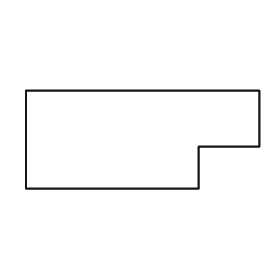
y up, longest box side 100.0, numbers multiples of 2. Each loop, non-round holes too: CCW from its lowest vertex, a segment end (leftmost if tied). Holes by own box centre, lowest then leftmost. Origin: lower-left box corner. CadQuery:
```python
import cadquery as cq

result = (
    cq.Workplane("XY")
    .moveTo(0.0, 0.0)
    .lineTo(74.0, 0.0)
    .lineTo(74.0, 18.0)
    .lineTo(100.0, 18.0)
    .lineTo(100.0, 42.0)
    .lineTo(0.0, 42.0)
    .close()
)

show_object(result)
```